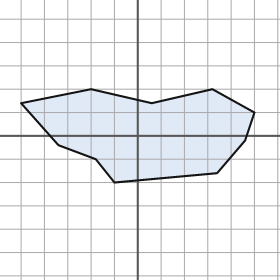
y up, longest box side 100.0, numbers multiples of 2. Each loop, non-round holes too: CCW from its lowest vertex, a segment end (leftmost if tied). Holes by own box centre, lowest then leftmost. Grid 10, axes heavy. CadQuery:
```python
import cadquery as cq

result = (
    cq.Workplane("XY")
    .moveTo(-10.0, -20.0)
    .lineTo(34.0, -16.0)
    .lineTo(46.0, -2.0)
    .lineTo(50.0, 10.0)
    .lineTo(32.0, 20.0)
    .lineTo(6.0, 14.0)
    .lineTo(-20.0, 20.0)
    .lineTo(-50.0, 14.0)
    .lineTo(-34.0, -4.0)
    .lineTo(-18.0, -10.0)
    .close()
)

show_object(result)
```